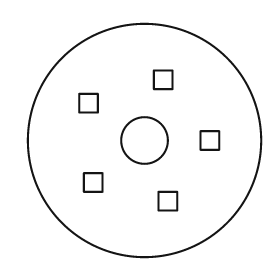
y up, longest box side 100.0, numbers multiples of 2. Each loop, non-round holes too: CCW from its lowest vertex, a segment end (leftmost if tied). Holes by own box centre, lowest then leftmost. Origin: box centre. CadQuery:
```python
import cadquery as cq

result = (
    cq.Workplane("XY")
    .moveTo(0.0, 0.0)
    .circle(50.0)
    .moveTo(6.0, -30.0)
    .lineTo(14.0, -30.0)
    .lineTo(14.0, -22.0)
    .lineTo(6.0, -22.0)
    .close()
    .moveTo(-26.0, -22.0)
    .lineTo(-18.0, -22.0)
    .lineTo(-18.0, -14.0)
    .lineTo(-26.0, -14.0)
    .close()
    .moveTo(0.0, 0.0)
    .circle(10.0)
    .moveTo(24.0, -4.0)
    .lineTo(32.0, -4.0)
    .lineTo(32.0, 4.0)
    .lineTo(24.0, 4.0)
    .close()
    .moveTo(-28.0, 12.0)
    .lineTo(-20.0, 12.0)
    .lineTo(-20.0, 20.0)
    .lineTo(-28.0, 20.0)
    .close()
    .moveTo(4.0, 22.0)
    .lineTo(12.0, 22.0)
    .lineTo(12.0, 30.0)
    .lineTo(4.0, 30.0)
    .close()
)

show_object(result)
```